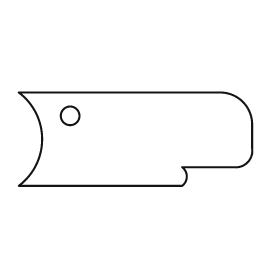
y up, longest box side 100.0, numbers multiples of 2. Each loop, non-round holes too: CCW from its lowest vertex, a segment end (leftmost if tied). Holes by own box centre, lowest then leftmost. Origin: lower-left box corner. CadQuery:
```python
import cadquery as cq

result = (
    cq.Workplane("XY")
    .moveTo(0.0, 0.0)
    .lineTo(70.0, 0.0)
    .threePointArc((72.0, 4.0), (70.0, 8.0))
    .lineTo(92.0, 8.0)
    .threePointArc((98.0, 10.0), (100.0, 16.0))
    .lineTo(100.0, 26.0)
    .threePointArc((96.0, 36.0), (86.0, 40.0))
    .lineTo(0.0, 40.0)
    .threePointArc((10.0, 20.0), (0.0, 0.0))
    .close()
    .moveTo(22.0, 30.0)
    .circle(4.0)
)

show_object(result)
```